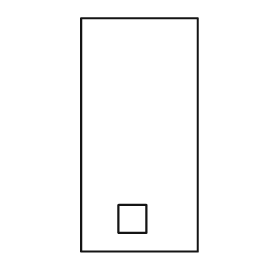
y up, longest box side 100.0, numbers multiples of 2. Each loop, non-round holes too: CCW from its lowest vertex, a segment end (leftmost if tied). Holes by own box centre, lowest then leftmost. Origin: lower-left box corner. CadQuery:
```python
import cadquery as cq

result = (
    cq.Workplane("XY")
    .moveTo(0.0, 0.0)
    .lineTo(50.0, 0.0)
    .lineTo(50.0, 100.0)
    .lineTo(0.0, 100.0)
    .close()
    .moveTo(16.0, 8.0)
    .lineTo(28.0, 8.0)
    .lineTo(28.0, 20.0)
    .lineTo(16.0, 20.0)
    .close()
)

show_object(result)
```